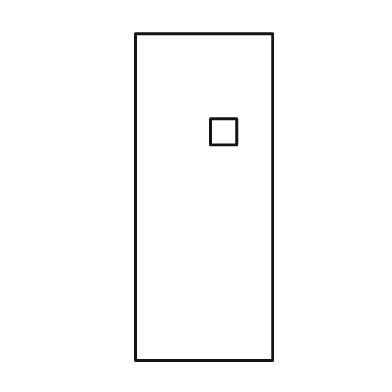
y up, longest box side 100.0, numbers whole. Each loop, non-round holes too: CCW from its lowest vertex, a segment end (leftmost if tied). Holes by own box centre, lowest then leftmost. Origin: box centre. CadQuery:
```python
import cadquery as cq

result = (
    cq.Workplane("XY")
    .moveTo(-21.0, -50.0)
    .lineTo(21.0, -50.0)
    .lineTo(21.0, 50.0)
    .lineTo(-21.0, 50.0)
    .close()
    .moveTo(2.0, 16.0)
    .lineTo(10.0, 16.0)
    .lineTo(10.0, 24.0)
    .lineTo(2.0, 24.0)
    .close()
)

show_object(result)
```